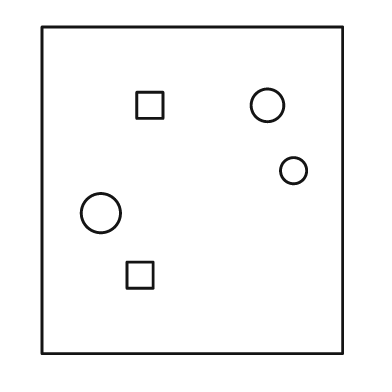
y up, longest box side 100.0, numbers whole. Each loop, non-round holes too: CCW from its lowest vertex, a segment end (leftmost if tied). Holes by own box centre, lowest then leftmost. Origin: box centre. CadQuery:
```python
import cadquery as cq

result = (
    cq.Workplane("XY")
    .moveTo(-46.0, -50.0)
    .lineTo(46.0, -50.0)
    .lineTo(46.0, 50.0)
    .lineTo(-46.0, 50.0)
    .close()
    .moveTo(-20.0, -30.0)
    .lineTo(-12.0, -30.0)
    .lineTo(-12.0, -22.0)
    .lineTo(-20.0, -22.0)
    .close()
    .moveTo(-28.0, -7.0)
    .circle(6.0)
    .moveTo(31.0, 6.0)
    .circle(4.0)
    .moveTo(-17.0, 22.0)
    .lineTo(-9.0, 22.0)
    .lineTo(-9.0, 30.0)
    .lineTo(-17.0, 30.0)
    .close()
    .moveTo(23.0, 26.0)
    .circle(5.0)
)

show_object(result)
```